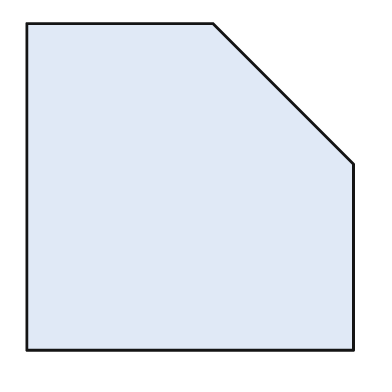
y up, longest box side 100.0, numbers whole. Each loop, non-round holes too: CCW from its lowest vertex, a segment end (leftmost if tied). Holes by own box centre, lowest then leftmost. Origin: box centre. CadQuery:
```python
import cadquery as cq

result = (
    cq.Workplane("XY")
    .moveTo(-50.0, -50.0)
    .lineTo(50.0, -50.0)
    .lineTo(50.0, 7.0)
    .lineTo(7.0, 50.0)
    .lineTo(-50.0, 50.0)
    .close()
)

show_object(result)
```